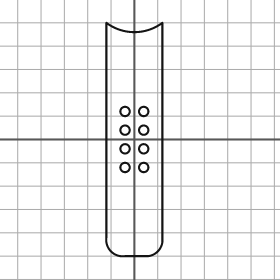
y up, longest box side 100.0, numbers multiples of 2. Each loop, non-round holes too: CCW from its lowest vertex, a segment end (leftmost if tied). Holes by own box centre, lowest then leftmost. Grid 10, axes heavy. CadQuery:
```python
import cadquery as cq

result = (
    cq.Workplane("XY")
    .moveTo(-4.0, -50.0)
    .lineTo(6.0, -50.0)
    .threePointArc((10.0, -48.0), (12.0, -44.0))
    .lineTo(12.0, 50.0)
    .threePointArc((0.0, 46.0), (-12.0, 50.0))
    .lineTo(-12.0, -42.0)
    .threePointArc((-10.0, -48.0), (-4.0, -50.0))
    .close()
    .moveTo(-4.0, -12.0)
    .circle(2.0)
    .moveTo(4.0, -12.0)
    .circle(2.0)
    .moveTo(-4.0, -4.0)
    .circle(2.0)
    .moveTo(4.0, -4.0)
    .circle(2.0)
    .moveTo(-4.0, 4.0)
    .circle(2.0)
    .moveTo(4.0, 4.0)
    .circle(2.0)
    .moveTo(-4.0, 12.0)
    .circle(2.0)
    .moveTo(4.0, 12.0)
    .circle(2.0)
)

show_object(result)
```